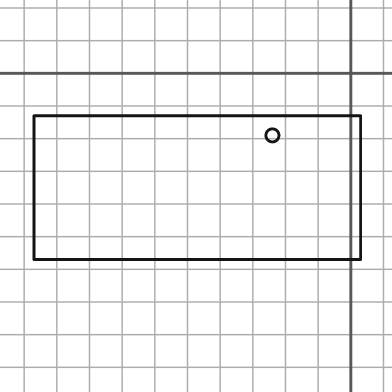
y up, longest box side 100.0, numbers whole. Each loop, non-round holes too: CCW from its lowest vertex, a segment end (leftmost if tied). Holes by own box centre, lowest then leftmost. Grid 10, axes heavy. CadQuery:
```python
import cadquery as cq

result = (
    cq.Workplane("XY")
    .moveTo(-97.0, -57.0)
    .lineTo(3.0, -57.0)
    .lineTo(3.0, -13.0)
    .lineTo(-97.0, -13.0)
    .close()
    .moveTo(-24.0, -19.0)
    .circle(2.0)
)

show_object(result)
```